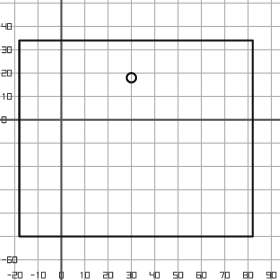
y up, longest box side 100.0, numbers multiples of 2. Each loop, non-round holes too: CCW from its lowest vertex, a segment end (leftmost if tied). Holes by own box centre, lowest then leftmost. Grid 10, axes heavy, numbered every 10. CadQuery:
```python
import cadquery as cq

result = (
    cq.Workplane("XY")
    .moveTo(-18.0, -50.0)
    .lineTo(82.0, -50.0)
    .lineTo(82.0, 34.0)
    .lineTo(-18.0, 34.0)
    .close()
    .moveTo(30.0, 18.0)
    .circle(2.0)
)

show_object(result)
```